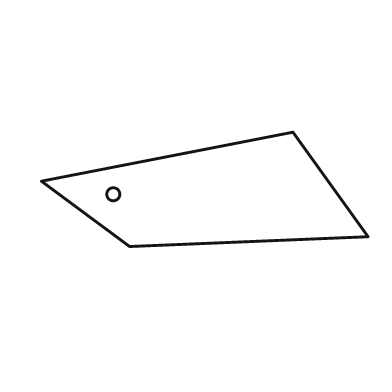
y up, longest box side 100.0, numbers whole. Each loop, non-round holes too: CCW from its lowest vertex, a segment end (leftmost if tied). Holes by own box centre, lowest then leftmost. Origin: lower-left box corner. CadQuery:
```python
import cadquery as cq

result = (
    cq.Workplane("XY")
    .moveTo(27.0, 0.0)
    .lineTo(100.0, 3.0)
    .lineTo(77.0, 35.0)
    .lineTo(0.0, 20.0)
    .close()
    .moveTo(22.0, 16.0)
    .circle(2.0)
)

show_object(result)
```